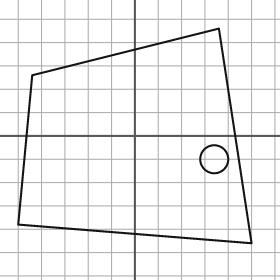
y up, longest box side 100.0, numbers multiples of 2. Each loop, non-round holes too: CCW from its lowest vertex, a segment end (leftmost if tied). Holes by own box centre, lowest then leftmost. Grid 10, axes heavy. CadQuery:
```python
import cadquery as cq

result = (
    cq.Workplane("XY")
    .moveTo(50.0, -46.0)
    .lineTo(36.0, 46.0)
    .lineTo(-44.0, 26.0)
    .lineTo(-50.0, -38.0)
    .close()
    .moveTo(34.0, -10.0)
    .circle(6.0)
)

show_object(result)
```